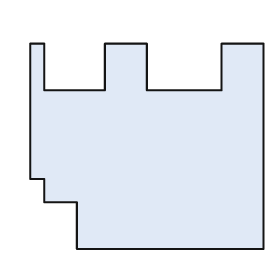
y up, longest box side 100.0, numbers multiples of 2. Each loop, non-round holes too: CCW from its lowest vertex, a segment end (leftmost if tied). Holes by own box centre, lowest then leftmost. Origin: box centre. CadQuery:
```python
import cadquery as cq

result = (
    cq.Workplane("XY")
    .moveTo(-30.0, -44.0)
    .lineTo(50.0, -44.0)
    .lineTo(50.0, 44.0)
    .lineTo(32.0, 44.0)
    .lineTo(32.0, 24.0)
    .lineTo(0.0, 24.0)
    .lineTo(0.0, 44.0)
    .lineTo(-18.0, 44.0)
    .lineTo(-18.0, 24.0)
    .lineTo(-44.0, 24.0)
    .lineTo(-44.0, 44.0)
    .lineTo(-50.0, 44.0)
    .lineTo(-50.0, -14.0)
    .lineTo(-44.0, -14.0)
    .lineTo(-44.0, -24.0)
    .lineTo(-30.0, -24.0)
    .close()
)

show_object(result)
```